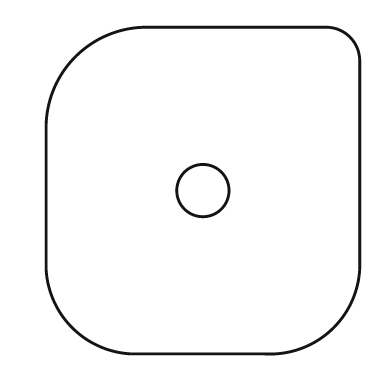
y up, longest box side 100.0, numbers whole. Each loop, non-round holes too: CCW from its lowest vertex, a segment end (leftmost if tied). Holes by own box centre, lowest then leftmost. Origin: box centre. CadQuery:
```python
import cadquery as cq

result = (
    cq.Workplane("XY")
    .moveTo(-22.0, -50.0)
    .lineTo(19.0, -50.0)
    .threePointArc((40.0, -42.0), (48.0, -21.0))
    .lineTo(48.0, 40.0)
    .threePointArc((45.0, 47.0), (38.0, 50.0))
    .lineTo(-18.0, 50.0)
    .threePointArc((-39.0, 41.0), (-48.0, 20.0))
    .lineTo(-48.0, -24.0)
    .threePointArc((-40.0, -42.0), (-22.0, -50.0))
    .close()
    .moveTo(0.0, 0.0)
    .circle(8.0)
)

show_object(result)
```